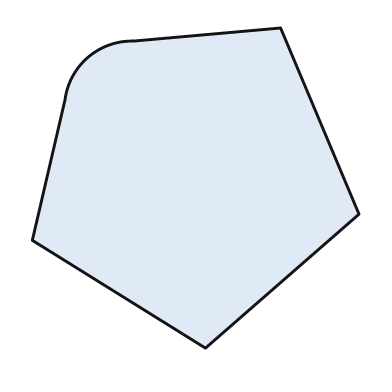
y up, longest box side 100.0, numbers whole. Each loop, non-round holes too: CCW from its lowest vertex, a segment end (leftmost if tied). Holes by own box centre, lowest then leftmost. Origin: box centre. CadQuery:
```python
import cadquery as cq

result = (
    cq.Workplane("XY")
    .moveTo(3.0, -49.0)
    .lineTo(50.0, -8.0)
    .lineTo(26.0, 49.0)
    .lineTo(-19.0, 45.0)
    .threePointArc((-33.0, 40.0), (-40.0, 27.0))
    .lineTo(-50.0, -16.0)
    .close()
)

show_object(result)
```